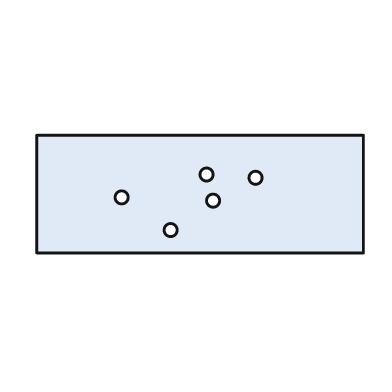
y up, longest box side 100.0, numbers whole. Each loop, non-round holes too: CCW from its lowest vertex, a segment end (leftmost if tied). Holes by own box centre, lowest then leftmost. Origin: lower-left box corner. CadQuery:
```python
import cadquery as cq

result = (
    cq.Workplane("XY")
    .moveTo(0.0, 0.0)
    .lineTo(100.0, 0.0)
    .lineTo(100.0, 36.0)
    .lineTo(0.0, 36.0)
    .close()
    .moveTo(41.0, 7.0)
    .circle(2.0)
    .moveTo(54.0, 16.0)
    .circle(2.0)
    .moveTo(26.0, 17.0)
    .circle(2.0)
    .moveTo(67.0, 23.0)
    .circle(2.0)
    .moveTo(52.0, 24.0)
    .circle(2.0)
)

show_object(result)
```